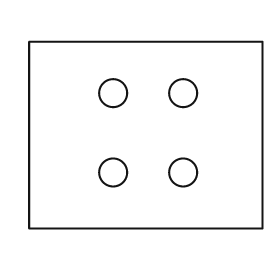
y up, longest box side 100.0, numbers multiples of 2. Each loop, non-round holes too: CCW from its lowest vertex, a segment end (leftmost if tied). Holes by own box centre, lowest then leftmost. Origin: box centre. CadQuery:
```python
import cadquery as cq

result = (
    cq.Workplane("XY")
    .moveTo(-50.0, -40.0)
    .lineTo(50.0, -40.0)
    .lineTo(50.0, 40.0)
    .lineTo(-50.0, 40.0)
    .close()
    .moveTo(-14.0, -16.0)
    .circle(6.0)
    .moveTo(16.0, -16.0)
    .circle(6.0)
    .moveTo(-14.0, 18.0)
    .circle(6.0)
    .moveTo(16.0, 18.0)
    .circle(6.0)
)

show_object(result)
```